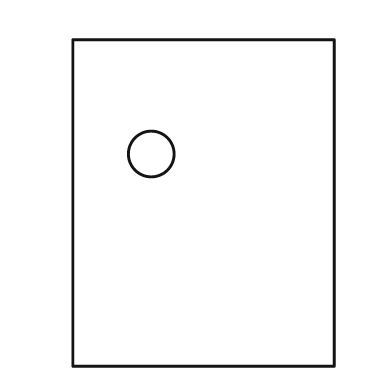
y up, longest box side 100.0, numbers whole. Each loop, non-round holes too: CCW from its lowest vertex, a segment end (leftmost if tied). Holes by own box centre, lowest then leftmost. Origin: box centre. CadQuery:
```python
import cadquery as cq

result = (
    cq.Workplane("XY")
    .moveTo(-40.0, -50.0)
    .lineTo(40.0, -50.0)
    .lineTo(40.0, 50.0)
    .lineTo(-40.0, 50.0)
    .close()
    .moveTo(-16.0, 15.0)
    .circle(7.0)
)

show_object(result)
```